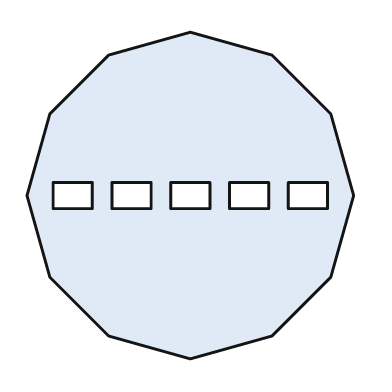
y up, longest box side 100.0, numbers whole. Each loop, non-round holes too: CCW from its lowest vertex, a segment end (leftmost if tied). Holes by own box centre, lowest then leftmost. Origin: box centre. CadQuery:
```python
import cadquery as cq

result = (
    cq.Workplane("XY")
    .moveTo(0.0, -50.0)
    .lineTo(25.0, -43.0)
    .lineTo(43.0, -25.0)
    .lineTo(50.0, 0.0)
    .lineTo(43.0, 25.0)
    .lineTo(25.0, 43.0)
    .lineTo(0.0, 50.0)
    .lineTo(-25.0, 43.0)
    .lineTo(-43.0, 25.0)
    .lineTo(-50.0, 0.0)
    .lineTo(-43.0, -25.0)
    .lineTo(-25.0, -43.0)
    .close()
    .moveTo(-42.0, -4.0)
    .lineTo(-30.0, -4.0)
    .lineTo(-30.0, 4.0)
    .lineTo(-42.0, 4.0)
    .close()
    .moveTo(-24.0, -4.0)
    .lineTo(-12.0, -4.0)
    .lineTo(-12.0, 4.0)
    .lineTo(-24.0, 4.0)
    .close()
    .moveTo(-6.0, -4.0)
    .lineTo(6.0, -4.0)
    .lineTo(6.0, 4.0)
    .lineTo(-6.0, 4.0)
    .close()
    .moveTo(12.0, -4.0)
    .lineTo(24.0, -4.0)
    .lineTo(24.0, 4.0)
    .lineTo(12.0, 4.0)
    .close()
    .moveTo(30.0, -4.0)
    .lineTo(42.0, -4.0)
    .lineTo(42.0, 4.0)
    .lineTo(30.0, 4.0)
    .close()
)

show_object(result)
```